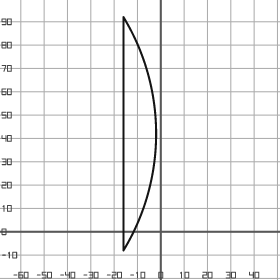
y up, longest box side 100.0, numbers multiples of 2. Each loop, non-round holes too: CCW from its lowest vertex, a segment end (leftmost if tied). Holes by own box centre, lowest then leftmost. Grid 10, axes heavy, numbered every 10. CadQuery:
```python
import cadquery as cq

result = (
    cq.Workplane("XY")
    .moveTo(-16.0, -8.0)
    .threePointArc((-2.0, 42.0), (-16.0, 92.0))
    .close()
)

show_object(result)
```